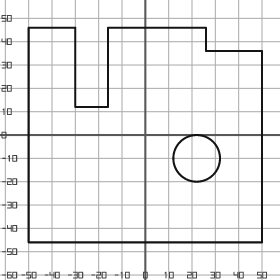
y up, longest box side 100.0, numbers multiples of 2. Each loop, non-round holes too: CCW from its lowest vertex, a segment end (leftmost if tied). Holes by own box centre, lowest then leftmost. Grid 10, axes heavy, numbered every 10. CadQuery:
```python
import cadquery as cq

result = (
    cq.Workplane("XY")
    .moveTo(-50.0, -46.0)
    .lineTo(50.0, -46.0)
    .lineTo(50.0, 36.0)
    .lineTo(26.0, 36.0)
    .lineTo(26.0, 46.0)
    .lineTo(-16.0, 46.0)
    .lineTo(-16.0, 12.0)
    .lineTo(-30.0, 12.0)
    .lineTo(-30.0, 46.0)
    .lineTo(-50.0, 46.0)
    .close()
    .moveTo(22.0, -10.0)
    .circle(10.0)
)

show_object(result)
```